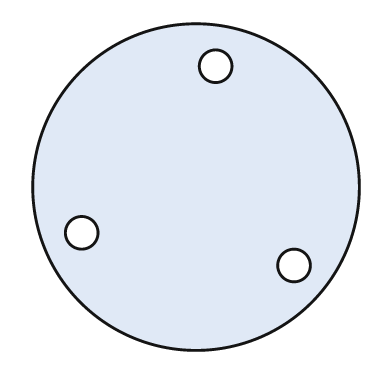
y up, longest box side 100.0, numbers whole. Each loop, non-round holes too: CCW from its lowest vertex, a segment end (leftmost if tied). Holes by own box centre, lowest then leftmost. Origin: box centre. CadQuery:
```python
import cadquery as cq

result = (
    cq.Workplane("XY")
    .moveTo(0.0, 0.0)
    .circle(50.0)
    .moveTo(30.0, -24.0)
    .circle(5.0)
    .moveTo(-35.0, -14.0)
    .circle(5.0)
    .moveTo(6.0, 37.0)
    .circle(5.0)
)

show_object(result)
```